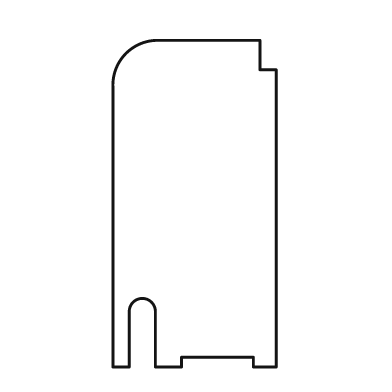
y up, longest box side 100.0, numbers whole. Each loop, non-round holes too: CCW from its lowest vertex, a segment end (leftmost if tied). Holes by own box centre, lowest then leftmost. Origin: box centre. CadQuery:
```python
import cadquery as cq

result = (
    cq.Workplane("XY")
    .moveTo(-25.0, -50.0)
    .lineTo(-20.0, -50.0)
    .lineTo(-20.0, -33.0)
    .threePointArc((-16.0, -29.0), (-12.0, -33.0))
    .lineTo(-12.0, -50.0)
    .lineTo(-4.0, -50.0)
    .lineTo(-4.0, -47.0)
    .lineTo(18.0, -47.0)
    .lineTo(18.0, -50.0)
    .lineTo(25.0, -50.0)
    .lineTo(25.0, 41.0)
    .lineTo(20.0, 41.0)
    .lineTo(20.0, 50.0)
    .lineTo(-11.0, 50.0)
    .threePointArc((-21.0, 46.0), (-25.0, 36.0))
    .close()
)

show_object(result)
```